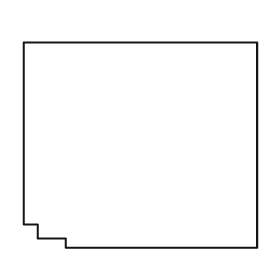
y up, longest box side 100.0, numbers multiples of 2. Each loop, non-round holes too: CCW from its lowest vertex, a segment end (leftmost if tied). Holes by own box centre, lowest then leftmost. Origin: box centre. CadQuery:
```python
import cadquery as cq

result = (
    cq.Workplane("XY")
    .moveTo(-32.0, -44.0)
    .lineTo(50.0, -44.0)
    .lineTo(50.0, 44.0)
    .lineTo(-50.0, 44.0)
    .lineTo(-50.0, -34.0)
    .lineTo(-44.0, -34.0)
    .lineTo(-44.0, -40.0)
    .lineTo(-32.0, -40.0)
    .close()
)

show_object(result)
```